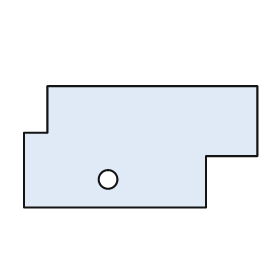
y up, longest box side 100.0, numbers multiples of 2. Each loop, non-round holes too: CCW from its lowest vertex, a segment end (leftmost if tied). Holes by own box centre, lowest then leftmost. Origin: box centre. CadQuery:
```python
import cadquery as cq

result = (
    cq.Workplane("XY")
    .moveTo(-50.0, -26.0)
    .lineTo(28.0, -26.0)
    .lineTo(28.0, -4.0)
    .lineTo(50.0, -4.0)
    .lineTo(50.0, 26.0)
    .lineTo(-40.0, 26.0)
    .lineTo(-40.0, 6.0)
    .lineTo(-50.0, 6.0)
    .close()
    .moveTo(-14.0, -14.0)
    .circle(4.0)
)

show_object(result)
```